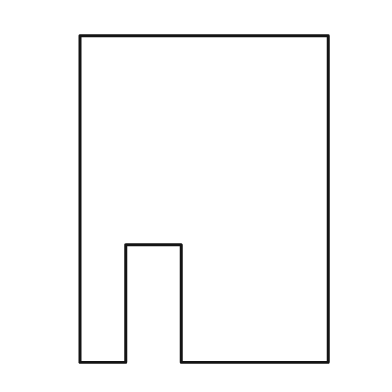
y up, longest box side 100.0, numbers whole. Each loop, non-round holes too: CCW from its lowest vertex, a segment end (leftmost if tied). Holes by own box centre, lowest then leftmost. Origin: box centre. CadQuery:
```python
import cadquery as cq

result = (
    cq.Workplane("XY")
    .moveTo(-38.0, -50.0)
    .lineTo(-24.0, -50.0)
    .lineTo(-24.0, -14.0)
    .lineTo(-7.0, -14.0)
    .lineTo(-7.0, -50.0)
    .lineTo(38.0, -50.0)
    .lineTo(38.0, 50.0)
    .lineTo(-38.0, 50.0)
    .close()
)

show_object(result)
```